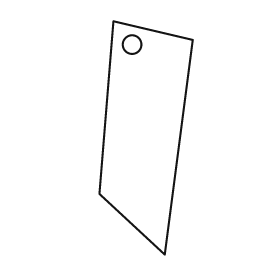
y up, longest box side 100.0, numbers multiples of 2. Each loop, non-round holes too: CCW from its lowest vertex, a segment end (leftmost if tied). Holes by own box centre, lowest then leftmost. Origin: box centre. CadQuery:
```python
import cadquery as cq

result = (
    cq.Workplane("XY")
    .moveTo(8.0, -50.0)
    .lineTo(20.0, 42.0)
    .lineTo(-14.0, 50.0)
    .lineTo(-20.0, -24.0)
    .close()
    .moveTo(-6.0, 40.0)
    .circle(4.0)
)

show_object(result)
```